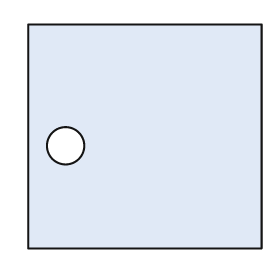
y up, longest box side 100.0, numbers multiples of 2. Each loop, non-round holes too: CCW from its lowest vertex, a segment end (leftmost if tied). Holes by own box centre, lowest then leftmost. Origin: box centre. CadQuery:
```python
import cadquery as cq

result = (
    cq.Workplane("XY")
    .moveTo(-50.0, -48.0)
    .lineTo(50.0, -48.0)
    .lineTo(50.0, 48.0)
    .lineTo(-50.0, 48.0)
    .close()
    .moveTo(-34.0, -4.0)
    .circle(8.0)
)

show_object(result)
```